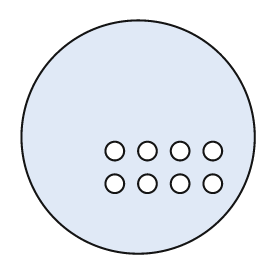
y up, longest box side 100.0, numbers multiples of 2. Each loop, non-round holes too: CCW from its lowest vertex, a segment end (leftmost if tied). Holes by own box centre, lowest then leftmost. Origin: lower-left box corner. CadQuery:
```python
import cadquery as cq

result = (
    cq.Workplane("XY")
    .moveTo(50.0, 50.0)
    .circle(50.0)
    .moveTo(40.0, 30.0)
    .circle(4.0)
    .moveTo(54.0, 30.0)
    .circle(4.0)
    .moveTo(68.0, 30.0)
    .circle(4.0)
    .moveTo(82.0, 30.0)
    .circle(4.0)
    .moveTo(40.0, 44.0)
    .circle(4.0)
    .moveTo(54.0, 44.0)
    .circle(4.0)
    .moveTo(68.0, 44.0)
    .circle(4.0)
    .moveTo(82.0, 44.0)
    .circle(4.0)
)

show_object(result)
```